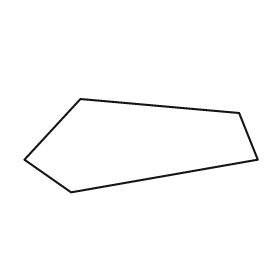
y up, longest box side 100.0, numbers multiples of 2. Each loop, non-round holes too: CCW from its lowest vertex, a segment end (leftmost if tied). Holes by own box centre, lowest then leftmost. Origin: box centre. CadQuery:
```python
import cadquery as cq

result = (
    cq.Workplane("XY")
    .moveTo(-30.0, -20.0)
    .lineTo(50.0, -6.0)
    .lineTo(42.0, 14.0)
    .lineTo(-26.0, 20.0)
    .lineTo(-50.0, -6.0)
    .close()
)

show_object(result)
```